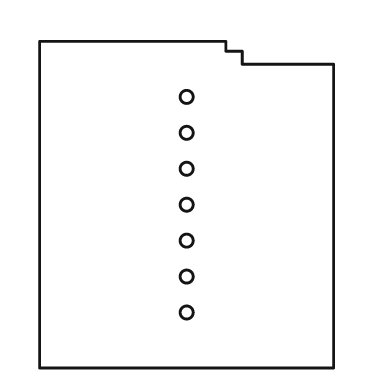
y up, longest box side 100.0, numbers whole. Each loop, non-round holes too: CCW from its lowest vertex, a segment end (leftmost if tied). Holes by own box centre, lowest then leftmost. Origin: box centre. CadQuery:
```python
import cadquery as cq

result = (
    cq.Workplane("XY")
    .moveTo(-45.0, -50.0)
    .lineTo(45.0, -50.0)
    .lineTo(45.0, 43.0)
    .lineTo(17.0, 43.0)
    .lineTo(17.0, 47.0)
    .lineTo(12.0, 47.0)
    .lineTo(12.0, 50.0)
    .lineTo(-45.0, 50.0)
    .close()
    .moveTo(0.0, -33.0)
    .circle(2.0)
    .moveTo(0.0, -22.0)
    .circle(2.0)
    .moveTo(0.0, -11.0)
    .circle(2.0)
    .moveTo(0.0, 0.0)
    .circle(2.0)
    .moveTo(0.0, 11.0)
    .circle(2.0)
    .moveTo(0.0, 22.0)
    .circle(2.0)
    .moveTo(0.0, 33.0)
    .circle(2.0)
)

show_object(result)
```